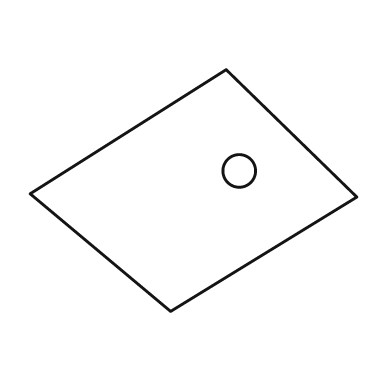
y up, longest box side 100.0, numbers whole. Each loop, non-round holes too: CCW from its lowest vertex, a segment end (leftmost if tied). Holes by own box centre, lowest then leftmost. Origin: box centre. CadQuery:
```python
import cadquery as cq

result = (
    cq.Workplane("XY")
    .moveTo(-7.0, -37.0)
    .lineTo(50.0, -2.0)
    .lineTo(10.0, 37.0)
    .lineTo(-50.0, -1.0)
    .close()
    .moveTo(14.0, 6.0)
    .circle(5.0)
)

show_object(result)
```